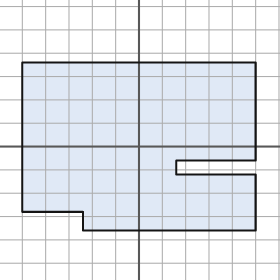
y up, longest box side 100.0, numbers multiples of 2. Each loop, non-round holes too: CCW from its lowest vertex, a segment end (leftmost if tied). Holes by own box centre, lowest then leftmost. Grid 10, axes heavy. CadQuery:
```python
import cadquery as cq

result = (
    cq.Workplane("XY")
    .moveTo(-24.0, -36.0)
    .lineTo(50.0, -36.0)
    .lineTo(50.0, -12.0)
    .lineTo(16.0, -12.0)
    .lineTo(16.0, -6.0)
    .lineTo(50.0, -6.0)
    .lineTo(50.0, 36.0)
    .lineTo(-50.0, 36.0)
    .lineTo(-50.0, -28.0)
    .lineTo(-24.0, -28.0)
    .close()
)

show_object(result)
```